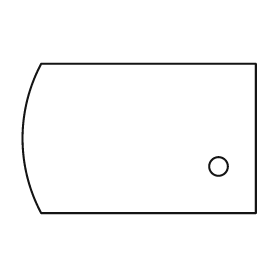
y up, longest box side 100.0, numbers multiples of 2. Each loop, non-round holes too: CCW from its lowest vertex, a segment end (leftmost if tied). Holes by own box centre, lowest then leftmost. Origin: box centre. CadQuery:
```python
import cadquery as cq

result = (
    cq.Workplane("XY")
    .moveTo(-42.0, -32.0)
    .lineTo(50.0, -32.0)
    .lineTo(50.0, 32.0)
    .lineTo(-42.0, 32.0)
    .threePointArc((-50.0, 0.0), (-42.0, -32.0))
    .close()
    .moveTo(34.0, -12.0)
    .circle(4.0)
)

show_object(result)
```